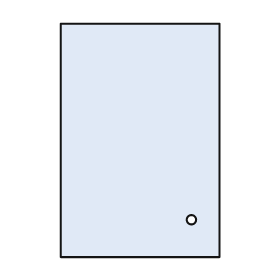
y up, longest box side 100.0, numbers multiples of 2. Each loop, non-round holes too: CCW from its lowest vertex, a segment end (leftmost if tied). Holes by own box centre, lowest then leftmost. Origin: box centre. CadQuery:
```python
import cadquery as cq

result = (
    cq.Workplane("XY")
    .moveTo(-34.0, -50.0)
    .lineTo(34.0, -50.0)
    .lineTo(34.0, 50.0)
    .lineTo(-34.0, 50.0)
    .close()
    .moveTo(22.0, -34.0)
    .circle(2.0)
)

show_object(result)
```